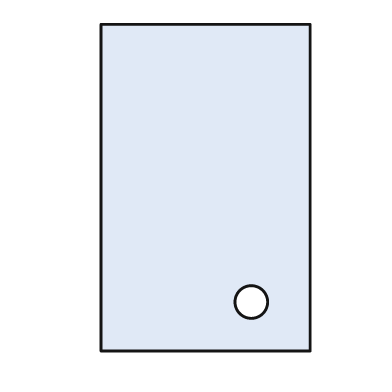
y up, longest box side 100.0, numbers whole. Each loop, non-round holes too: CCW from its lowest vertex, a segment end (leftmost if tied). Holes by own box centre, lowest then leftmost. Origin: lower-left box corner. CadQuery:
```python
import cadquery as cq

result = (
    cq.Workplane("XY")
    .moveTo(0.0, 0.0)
    .lineTo(64.0, 0.0)
    .lineTo(64.0, 100.0)
    .lineTo(0.0, 100.0)
    .close()
    .moveTo(46.0, 15.0)
    .circle(5.0)
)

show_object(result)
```